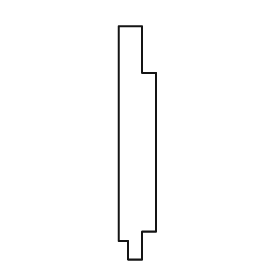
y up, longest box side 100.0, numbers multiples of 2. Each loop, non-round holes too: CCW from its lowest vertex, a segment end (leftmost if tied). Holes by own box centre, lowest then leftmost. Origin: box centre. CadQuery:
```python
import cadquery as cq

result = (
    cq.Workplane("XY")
    .moveTo(-4.0, -50.0)
    .lineTo(2.0, -50.0)
    .lineTo(2.0, -38.0)
    .lineTo(8.0, -38.0)
    .lineTo(8.0, 30.0)
    .lineTo(2.0, 30.0)
    .lineTo(2.0, 50.0)
    .lineTo(-8.0, 50.0)
    .lineTo(-8.0, -42.0)
    .lineTo(-4.0, -42.0)
    .close()
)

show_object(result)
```